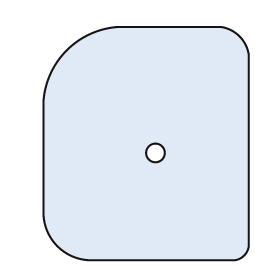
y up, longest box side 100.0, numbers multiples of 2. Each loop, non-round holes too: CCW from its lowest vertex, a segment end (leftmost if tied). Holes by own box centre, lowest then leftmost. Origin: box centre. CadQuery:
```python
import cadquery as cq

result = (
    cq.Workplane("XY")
    .moveTo(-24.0, -50.0)
    .lineTo(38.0, -50.0)
    .threePointArc((42.0, -48.0), (44.0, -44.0))
    .lineTo(44.0, 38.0)
    .threePointArc((40.0, 46.0), (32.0, 50.0))
    .lineTo(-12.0, 50.0)
    .threePointArc((-34.0, 40.0), (-44.0, 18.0))
    .lineTo(-44.0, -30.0)
    .threePointArc((-38.0, -44.0), (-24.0, -50.0))
    .close()
    .moveTo(4.0, -4.0)
    .circle(4.0)
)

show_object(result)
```